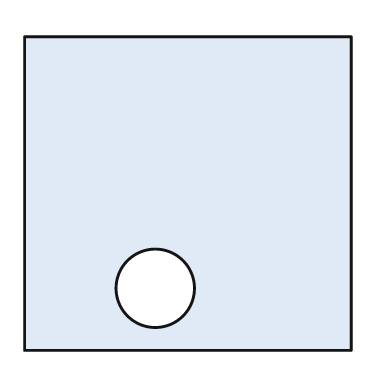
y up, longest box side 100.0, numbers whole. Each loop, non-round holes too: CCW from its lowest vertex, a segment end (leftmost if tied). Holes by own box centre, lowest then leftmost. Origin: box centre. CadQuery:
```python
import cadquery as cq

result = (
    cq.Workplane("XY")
    .moveTo(-50.0, -48.0)
    .lineTo(50.0, -48.0)
    .lineTo(50.0, 48.0)
    .lineTo(-50.0, 48.0)
    .close()
    .moveTo(-10.0, -29.0)
    .circle(12.0)
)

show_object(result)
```